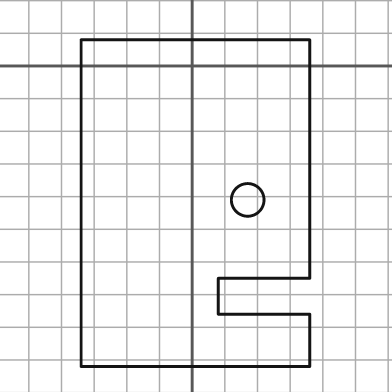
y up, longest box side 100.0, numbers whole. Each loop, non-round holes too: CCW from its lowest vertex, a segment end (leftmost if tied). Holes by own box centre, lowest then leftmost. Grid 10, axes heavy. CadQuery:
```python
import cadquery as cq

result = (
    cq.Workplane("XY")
    .moveTo(-34.0, -92.0)
    .lineTo(36.0, -92.0)
    .lineTo(36.0, -76.0)
    .lineTo(8.0, -76.0)
    .lineTo(8.0, -65.0)
    .lineTo(36.0, -65.0)
    .lineTo(36.0, 8.0)
    .lineTo(-34.0, 8.0)
    .close()
    .moveTo(17.0, -41.0)
    .circle(5.0)
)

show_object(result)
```